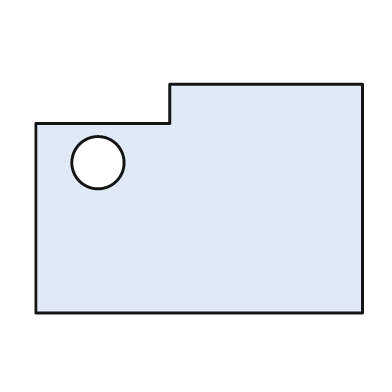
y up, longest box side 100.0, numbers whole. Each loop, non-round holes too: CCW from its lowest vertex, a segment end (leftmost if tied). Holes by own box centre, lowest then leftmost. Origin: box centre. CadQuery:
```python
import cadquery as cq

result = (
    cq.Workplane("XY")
    .moveTo(-50.0, -35.0)
    .lineTo(50.0, -35.0)
    .lineTo(50.0, 35.0)
    .lineTo(-9.0, 35.0)
    .lineTo(-9.0, 23.0)
    .lineTo(-50.0, 23.0)
    .close()
    .moveTo(-31.0, 11.0)
    .circle(8.0)
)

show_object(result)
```